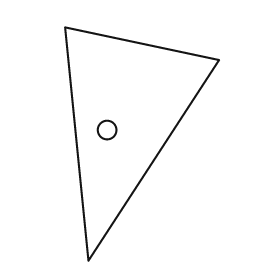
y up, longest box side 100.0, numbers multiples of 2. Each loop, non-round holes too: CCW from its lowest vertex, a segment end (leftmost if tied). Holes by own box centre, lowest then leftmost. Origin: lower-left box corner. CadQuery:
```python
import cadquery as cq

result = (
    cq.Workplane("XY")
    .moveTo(10.0, 0.0)
    .lineTo(66.0, 86.0)
    .lineTo(0.0, 100.0)
    .close()
    .moveTo(18.0, 56.0)
    .circle(4.0)
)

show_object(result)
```